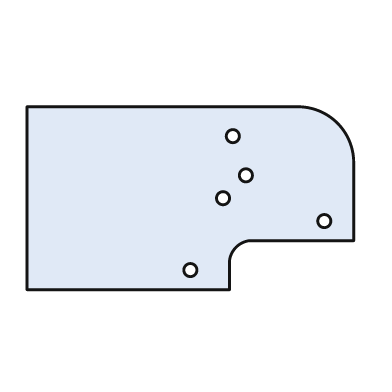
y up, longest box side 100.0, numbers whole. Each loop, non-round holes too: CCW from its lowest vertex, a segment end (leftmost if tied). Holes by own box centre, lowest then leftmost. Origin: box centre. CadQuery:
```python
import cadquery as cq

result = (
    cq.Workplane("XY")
    .moveTo(-50.0, -28.0)
    .lineTo(12.0, -28.0)
    .lineTo(12.0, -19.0)
    .threePointArc((14.0, -15.0), (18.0, -13.0))
    .lineTo(50.0, -13.0)
    .lineTo(50.0, 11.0)
    .threePointArc((45.0, 23.0), (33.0, 28.0))
    .lineTo(-50.0, 28.0)
    .close()
    .moveTo(0.0, -22.0)
    .circle(2.0)
    .moveTo(41.0, -7.0)
    .circle(2.0)
    .moveTo(10.0, 0.0)
    .circle(2.0)
    .moveTo(17.0, 7.0)
    .circle(2.0)
    .moveTo(13.0, 19.0)
    .circle(2.0)
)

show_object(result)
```